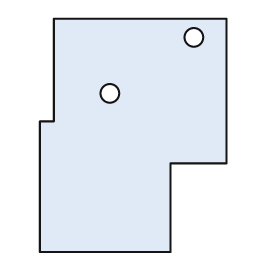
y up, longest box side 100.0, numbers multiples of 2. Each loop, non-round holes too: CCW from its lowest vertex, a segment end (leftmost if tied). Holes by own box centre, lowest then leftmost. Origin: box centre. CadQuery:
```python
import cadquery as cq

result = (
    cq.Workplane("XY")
    .moveTo(-40.0, -50.0)
    .lineTo(16.0, -50.0)
    .lineTo(16.0, -12.0)
    .lineTo(40.0, -12.0)
    .lineTo(40.0, 50.0)
    .lineTo(-34.0, 50.0)
    .lineTo(-34.0, 6.0)
    .lineTo(-40.0, 6.0)
    .close()
    .moveTo(-10.0, 18.0)
    .circle(4.0)
    .moveTo(26.0, 42.0)
    .circle(4.0)
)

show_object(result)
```